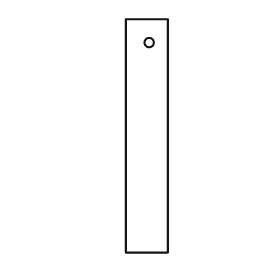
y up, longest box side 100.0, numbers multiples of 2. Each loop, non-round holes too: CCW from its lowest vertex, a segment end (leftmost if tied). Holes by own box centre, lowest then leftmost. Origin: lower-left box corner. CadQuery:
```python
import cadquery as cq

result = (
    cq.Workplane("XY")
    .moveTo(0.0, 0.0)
    .lineTo(18.0, 0.0)
    .lineTo(18.0, 100.0)
    .lineTo(0.0, 100.0)
    .close()
    .moveTo(10.0, 90.0)
    .circle(2.0)
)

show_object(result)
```